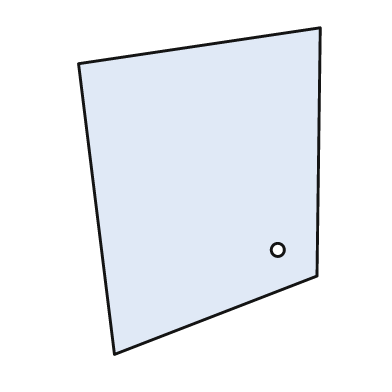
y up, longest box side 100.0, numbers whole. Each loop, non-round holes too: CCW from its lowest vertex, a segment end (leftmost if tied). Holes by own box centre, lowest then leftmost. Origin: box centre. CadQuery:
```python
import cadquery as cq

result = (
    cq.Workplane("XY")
    .moveTo(-26.0, -50.0)
    .lineTo(36.0, -26.0)
    .lineTo(37.0, 50.0)
    .lineTo(-37.0, 39.0)
    .close()
    .moveTo(24.0, -18.0)
    .circle(2.0)
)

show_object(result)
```